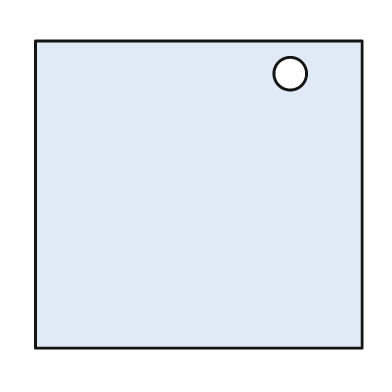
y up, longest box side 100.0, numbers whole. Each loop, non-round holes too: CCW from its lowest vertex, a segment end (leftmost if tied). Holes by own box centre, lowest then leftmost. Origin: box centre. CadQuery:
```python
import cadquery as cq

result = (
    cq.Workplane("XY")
    .moveTo(-50.0, -47.0)
    .lineTo(50.0, -47.0)
    .lineTo(50.0, 47.0)
    .lineTo(-50.0, 47.0)
    .close()
    .moveTo(28.0, 37.0)
    .circle(5.0)
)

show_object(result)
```